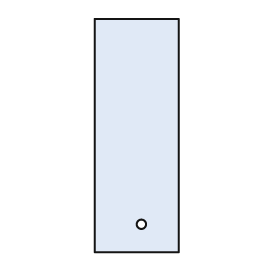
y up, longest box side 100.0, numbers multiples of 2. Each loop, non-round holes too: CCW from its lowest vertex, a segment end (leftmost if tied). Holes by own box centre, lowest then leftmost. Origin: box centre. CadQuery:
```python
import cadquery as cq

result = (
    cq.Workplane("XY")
    .moveTo(-18.0, -50.0)
    .lineTo(18.0, -50.0)
    .lineTo(18.0, 50.0)
    .lineTo(-18.0, 50.0)
    .close()
    .moveTo(2.0, -38.0)
    .circle(2.0)
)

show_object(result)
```